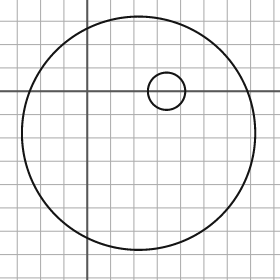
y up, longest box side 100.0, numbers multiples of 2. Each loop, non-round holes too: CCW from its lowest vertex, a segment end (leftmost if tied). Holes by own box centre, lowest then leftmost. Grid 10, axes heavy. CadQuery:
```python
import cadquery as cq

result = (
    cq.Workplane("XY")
    .moveTo(22.0, -18.0)
    .circle(50.0)
    .moveTo(34.0, 0.0)
    .circle(8.0)
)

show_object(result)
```